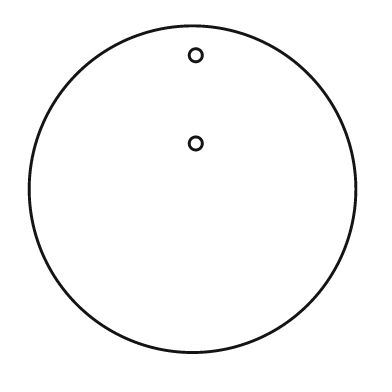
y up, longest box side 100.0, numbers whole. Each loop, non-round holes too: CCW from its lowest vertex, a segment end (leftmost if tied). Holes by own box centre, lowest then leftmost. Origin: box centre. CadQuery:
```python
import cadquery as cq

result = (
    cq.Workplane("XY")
    .moveTo(0.0, 0.0)
    .circle(50.0)
    .moveTo(1.0, 14.0)
    .circle(2.0)
    .moveTo(1.0, 41.0)
    .circle(2.0)
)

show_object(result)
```